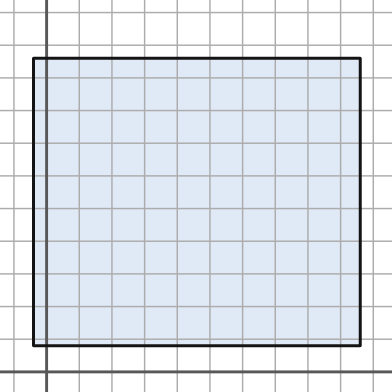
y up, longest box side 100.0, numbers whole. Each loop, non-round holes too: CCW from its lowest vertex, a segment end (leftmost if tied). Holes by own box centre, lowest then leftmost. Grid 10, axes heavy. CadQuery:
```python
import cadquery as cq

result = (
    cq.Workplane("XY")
    .moveTo(-4.0, 8.0)
    .lineTo(96.0, 8.0)
    .lineTo(96.0, 96.0)
    .lineTo(-4.0, 96.0)
    .close()
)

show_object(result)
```